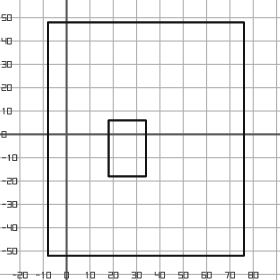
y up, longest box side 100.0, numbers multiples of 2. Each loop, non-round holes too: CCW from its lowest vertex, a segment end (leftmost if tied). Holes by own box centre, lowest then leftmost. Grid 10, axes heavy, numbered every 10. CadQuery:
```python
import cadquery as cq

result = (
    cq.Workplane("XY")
    .moveTo(-8.0, -52.0)
    .lineTo(76.0, -52.0)
    .lineTo(76.0, 48.0)
    .lineTo(-8.0, 48.0)
    .close()
    .moveTo(18.0, -18.0)
    .lineTo(34.0, -18.0)
    .lineTo(34.0, 6.0)
    .lineTo(18.0, 6.0)
    .close()
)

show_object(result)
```